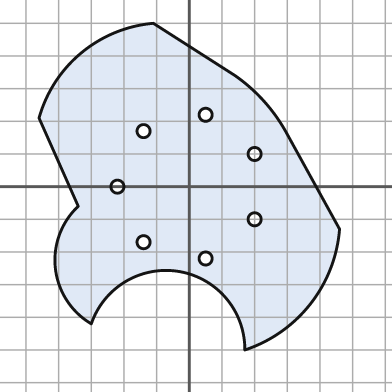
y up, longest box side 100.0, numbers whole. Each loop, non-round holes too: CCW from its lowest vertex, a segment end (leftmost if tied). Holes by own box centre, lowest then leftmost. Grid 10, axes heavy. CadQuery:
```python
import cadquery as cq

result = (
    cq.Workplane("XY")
    .moveTo(17.0, -50.0)
    .threePointArc((37.0, -36.0), (46.0, -13.0))
    .lineTo(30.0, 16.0)
    .threePointArc((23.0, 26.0), (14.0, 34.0))
    .lineTo(-11.0, 50.0)
    .threePointArc((-33.0, 41.0), (-46.0, 21.0))
    .lineTo(-34.0, -6.0)
    .threePointArc((-41.0, -25.0), (-30.0, -42.0))
    .threePointArc((-3.0, -26.0), (17.0, -50.0))
    .close()
    .moveTo(5.0, -22.0)
    .circle(2.0)
    .moveTo(-14.0, -17.0)
    .circle(2.0)
    .moveTo(20.0, -10.0)
    .circle(2.0)
    .moveTo(-22.0, 0.0)
    .circle(2.0)
    .moveTo(20.0, 10.0)
    .circle(2.0)
    .moveTo(-14.0, 17.0)
    .circle(2.0)
    .moveTo(5.0, 22.0)
    .circle(2.0)
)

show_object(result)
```